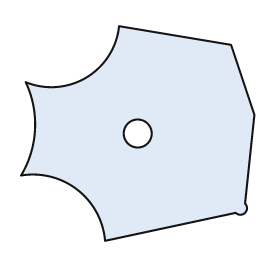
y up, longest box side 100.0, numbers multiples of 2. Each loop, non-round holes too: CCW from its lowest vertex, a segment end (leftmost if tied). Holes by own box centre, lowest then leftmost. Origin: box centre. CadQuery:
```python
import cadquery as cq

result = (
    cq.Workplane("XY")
    .moveTo(-14.0, -46.0)
    .lineTo(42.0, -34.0)
    .threePointArc((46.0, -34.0), (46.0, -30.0))
    .lineTo(50.0, 8.0)
    .lineTo(40.0, 38.0)
    .lineTo(-8.0, 46.0)
    .threePointArc((-22.0, 24.0), (-48.0, 22.0))
    .threePointArc((-44.0, 2.0), (-50.0, -18.0))
    .threePointArc((-26.0, -24.0), (-14.0, -46.0))
    .close()
    .moveTo(0.0, 0.0)
    .circle(6.0)
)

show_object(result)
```